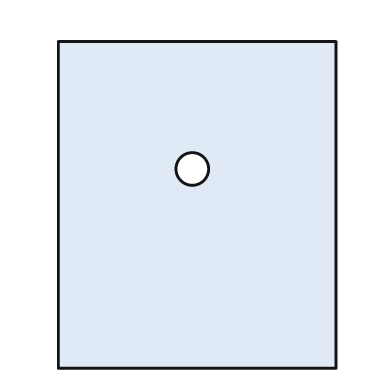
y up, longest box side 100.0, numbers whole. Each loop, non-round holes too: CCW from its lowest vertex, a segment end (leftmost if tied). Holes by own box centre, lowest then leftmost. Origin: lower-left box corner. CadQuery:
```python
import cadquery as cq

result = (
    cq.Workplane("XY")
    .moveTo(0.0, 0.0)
    .lineTo(85.0, 0.0)
    .lineTo(85.0, 100.0)
    .lineTo(0.0, 100.0)
    .close()
    .moveTo(41.0, 61.0)
    .circle(5.0)
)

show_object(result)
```